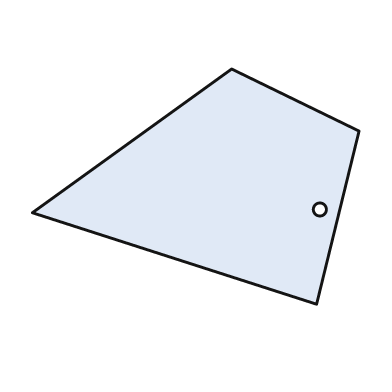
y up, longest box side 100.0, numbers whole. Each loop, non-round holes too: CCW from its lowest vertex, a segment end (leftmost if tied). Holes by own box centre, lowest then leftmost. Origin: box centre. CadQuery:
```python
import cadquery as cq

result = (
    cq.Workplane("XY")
    .moveTo(37.0, -36.0)
    .lineTo(50.0, 17.0)
    .lineTo(11.0, 36.0)
    .lineTo(-50.0, -8.0)
    .close()
    .moveTo(38.0, -7.0)
    .circle(2.0)
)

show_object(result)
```